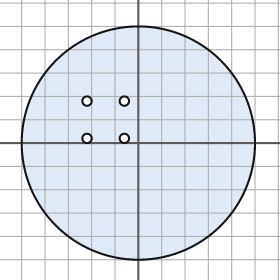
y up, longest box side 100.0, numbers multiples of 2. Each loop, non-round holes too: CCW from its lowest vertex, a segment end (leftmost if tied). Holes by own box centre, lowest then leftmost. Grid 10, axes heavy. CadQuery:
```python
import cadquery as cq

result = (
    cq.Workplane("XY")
    .moveTo(0.0, 0.0)
    .circle(50.0)
    .moveTo(-22.0, 2.0)
    .circle(2.0)
    .moveTo(-6.0, 2.0)
    .circle(2.0)
    .moveTo(-22.0, 18.0)
    .circle(2.0)
    .moveTo(-6.0, 18.0)
    .circle(2.0)
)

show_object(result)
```